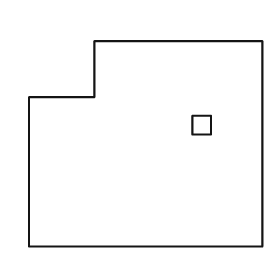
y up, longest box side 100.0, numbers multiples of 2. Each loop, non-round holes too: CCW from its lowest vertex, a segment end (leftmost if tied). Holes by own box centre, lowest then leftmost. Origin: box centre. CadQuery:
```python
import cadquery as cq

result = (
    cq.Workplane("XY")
    .moveTo(-50.0, -44.0)
    .lineTo(50.0, -44.0)
    .lineTo(50.0, 44.0)
    .lineTo(-22.0, 44.0)
    .lineTo(-22.0, 20.0)
    .lineTo(-50.0, 20.0)
    .close()
    .moveTo(20.0, 4.0)
    .lineTo(28.0, 4.0)
    .lineTo(28.0, 12.0)
    .lineTo(20.0, 12.0)
    .close()
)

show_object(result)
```